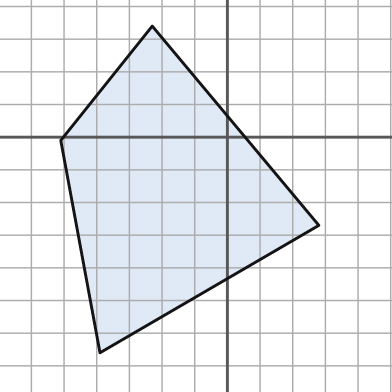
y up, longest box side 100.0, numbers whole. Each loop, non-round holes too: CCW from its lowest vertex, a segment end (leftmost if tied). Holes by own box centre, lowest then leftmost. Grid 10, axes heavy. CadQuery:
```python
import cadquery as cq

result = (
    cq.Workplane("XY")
    .moveTo(-39.0, -66.0)
    .lineTo(28.0, -27.0)
    .lineTo(-23.0, 34.0)
    .lineTo(-51.0, -1.0)
    .close()
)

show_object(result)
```